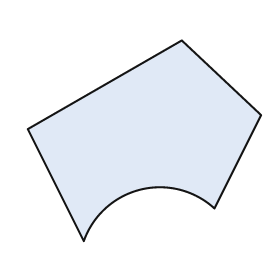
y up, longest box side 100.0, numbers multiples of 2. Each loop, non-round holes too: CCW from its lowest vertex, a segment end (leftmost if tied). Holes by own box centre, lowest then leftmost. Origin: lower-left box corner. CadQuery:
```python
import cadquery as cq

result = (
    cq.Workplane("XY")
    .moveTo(24.0, 0.0)
    .threePointArc((48.0, 22.0), (80.0, 14.0))
    .lineTo(100.0, 54.0)
    .lineTo(66.0, 86.0)
    .lineTo(0.0, 48.0)
    .close()
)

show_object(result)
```